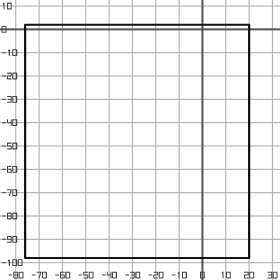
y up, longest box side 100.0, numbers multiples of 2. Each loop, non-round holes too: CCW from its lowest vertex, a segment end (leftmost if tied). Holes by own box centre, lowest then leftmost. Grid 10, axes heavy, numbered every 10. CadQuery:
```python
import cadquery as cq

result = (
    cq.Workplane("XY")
    .moveTo(-76.0, -98.0)
    .lineTo(20.0, -98.0)
    .lineTo(20.0, 2.0)
    .lineTo(-76.0, 2.0)
    .close()
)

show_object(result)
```